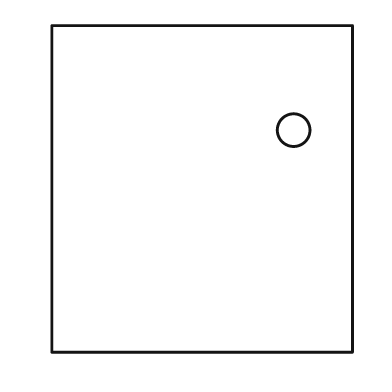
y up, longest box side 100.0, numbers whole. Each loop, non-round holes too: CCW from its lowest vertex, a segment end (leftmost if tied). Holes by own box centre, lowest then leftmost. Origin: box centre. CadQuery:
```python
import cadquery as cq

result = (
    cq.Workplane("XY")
    .moveTo(-46.0, -50.0)
    .lineTo(46.0, -50.0)
    .lineTo(46.0, 50.0)
    .lineTo(-46.0, 50.0)
    .close()
    .moveTo(28.0, 18.0)
    .circle(5.0)
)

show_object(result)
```